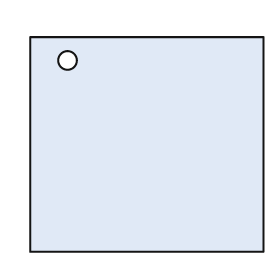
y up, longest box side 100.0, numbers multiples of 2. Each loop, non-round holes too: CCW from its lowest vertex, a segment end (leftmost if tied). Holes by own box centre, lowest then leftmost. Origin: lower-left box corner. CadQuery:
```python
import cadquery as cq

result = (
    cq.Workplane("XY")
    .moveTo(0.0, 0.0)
    .lineTo(100.0, 0.0)
    .lineTo(100.0, 92.0)
    .lineTo(0.0, 92.0)
    .close()
    .moveTo(16.0, 82.0)
    .circle(4.0)
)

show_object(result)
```